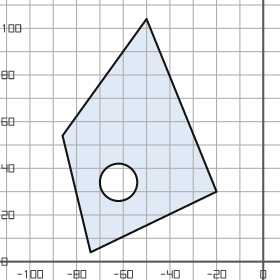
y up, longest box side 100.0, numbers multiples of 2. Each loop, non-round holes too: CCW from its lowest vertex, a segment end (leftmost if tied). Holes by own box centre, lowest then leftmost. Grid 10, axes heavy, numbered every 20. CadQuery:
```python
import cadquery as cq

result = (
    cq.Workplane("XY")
    .moveTo(-74.0, 4.0)
    .lineTo(-20.0, 30.0)
    .lineTo(-50.0, 104.0)
    .lineTo(-86.0, 54.0)
    .close()
    .moveTo(-62.0, 34.0)
    .circle(8.0)
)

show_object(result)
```